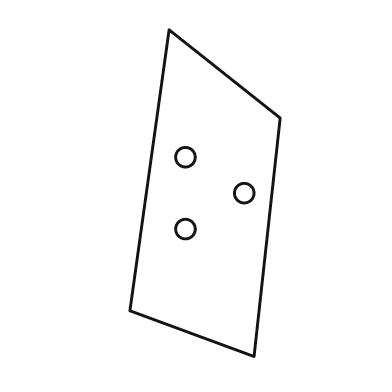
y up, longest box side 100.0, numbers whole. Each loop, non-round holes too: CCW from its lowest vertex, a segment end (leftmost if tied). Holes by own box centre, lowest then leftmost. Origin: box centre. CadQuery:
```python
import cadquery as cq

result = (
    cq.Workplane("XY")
    .moveTo(15.0, -50.0)
    .lineTo(23.0, 23.0)
    .lineTo(-11.0, 50.0)
    .lineTo(-23.0, -36.0)
    .close()
    .moveTo(-6.0, -11.0)
    .circle(3.0)
    .moveTo(12.0, 0.0)
    .circle(3.0)
    .moveTo(-6.0, 11.0)
    .circle(3.0)
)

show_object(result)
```